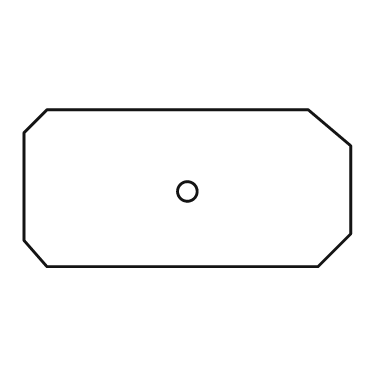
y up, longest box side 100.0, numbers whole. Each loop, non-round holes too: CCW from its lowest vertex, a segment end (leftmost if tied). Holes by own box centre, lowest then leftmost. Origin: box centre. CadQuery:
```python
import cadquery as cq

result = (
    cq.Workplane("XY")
    .moveTo(-43.0, -24.0)
    .lineTo(40.0, -24.0)
    .lineTo(50.0, -14.0)
    .lineTo(50.0, 13.0)
    .lineTo(37.0, 24.0)
    .lineTo(-43.0, 24.0)
    .lineTo(-50.0, 17.0)
    .lineTo(-50.0, -16.0)
    .close()
    .moveTo(0.0, -1.0)
    .circle(3.0)
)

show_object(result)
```